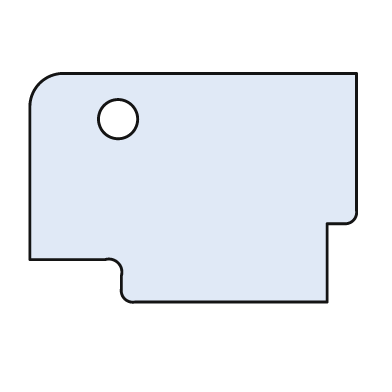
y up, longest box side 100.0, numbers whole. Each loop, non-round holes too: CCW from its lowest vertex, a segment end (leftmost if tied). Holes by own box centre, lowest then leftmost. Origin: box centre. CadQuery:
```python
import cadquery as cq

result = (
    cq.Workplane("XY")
    .moveTo(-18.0, -35.0)
    .lineTo(41.0, -35.0)
    .lineTo(41.0, -11.0)
    .lineTo(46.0, -11.0)
    .threePointArc((49.0, -10.0), (50.0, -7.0))
    .lineTo(50.0, 35.0)
    .lineTo(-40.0, 35.0)
    .threePointArc((-47.0, 32.0), (-50.0, 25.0))
    .lineTo(-50.0, -22.0)
    .lineTo(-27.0, -22.0)
    .threePointArc((-23.0, -23.0), (-22.0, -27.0))
    .lineTo(-22.0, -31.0)
    .threePointArc((-21.0, -34.0), (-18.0, -35.0))
    .close()
    .moveTo(-23.0, 21.0)
    .circle(6.0)
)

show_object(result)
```